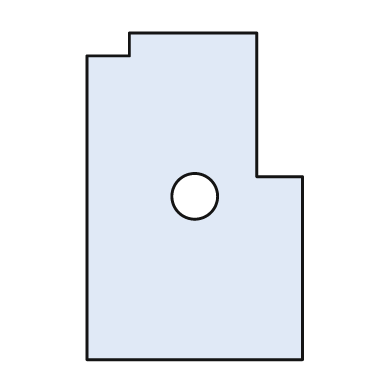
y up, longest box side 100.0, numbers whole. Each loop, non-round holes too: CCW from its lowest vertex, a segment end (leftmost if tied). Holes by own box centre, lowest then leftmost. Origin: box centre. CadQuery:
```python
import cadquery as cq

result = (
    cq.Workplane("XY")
    .moveTo(-33.0, -50.0)
    .lineTo(33.0, -50.0)
    .lineTo(33.0, 6.0)
    .lineTo(19.0, 6.0)
    .lineTo(19.0, 50.0)
    .lineTo(-20.0, 50.0)
    .lineTo(-20.0, 43.0)
    .lineTo(-33.0, 43.0)
    .close()
    .moveTo(0.0, 0.0)
    .circle(7.0)
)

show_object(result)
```